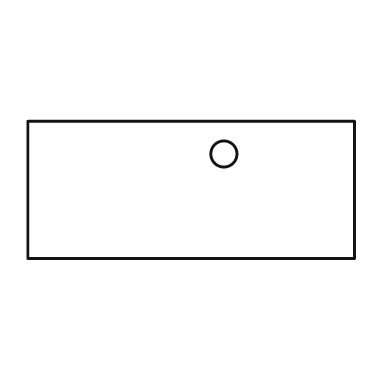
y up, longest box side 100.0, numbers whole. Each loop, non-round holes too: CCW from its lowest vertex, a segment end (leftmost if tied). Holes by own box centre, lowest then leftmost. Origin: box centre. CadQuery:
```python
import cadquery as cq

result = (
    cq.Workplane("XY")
    .moveTo(-50.0, -21.0)
    .lineTo(50.0, -21.0)
    .lineTo(50.0, 21.0)
    .lineTo(-50.0, 21.0)
    .close()
    .moveTo(10.0, 11.0)
    .circle(4.0)
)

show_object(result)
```